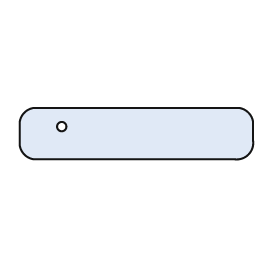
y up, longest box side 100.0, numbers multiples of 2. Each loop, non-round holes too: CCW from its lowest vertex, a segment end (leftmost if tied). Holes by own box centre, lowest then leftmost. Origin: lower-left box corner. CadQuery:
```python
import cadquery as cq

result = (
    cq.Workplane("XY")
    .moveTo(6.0, 0.0)
    .lineTo(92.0, 0.0)
    .threePointArc((98.0, 2.0), (100.0, 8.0))
    .lineTo(100.0, 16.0)
    .threePointArc((98.0, 20.0), (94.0, 22.0))
    .lineTo(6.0, 22.0)
    .threePointArc((2.0, 20.0), (0.0, 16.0))
    .lineTo(0.0, 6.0)
    .threePointArc((2.0, 2.0), (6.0, 0.0))
    .close()
    .moveTo(18.0, 14.0)
    .circle(2.0)
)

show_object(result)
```